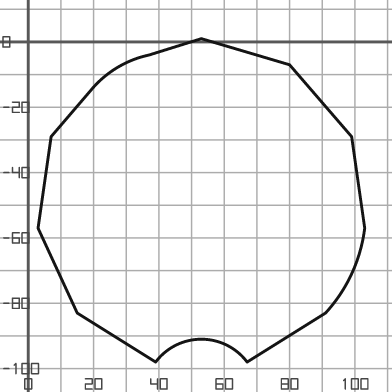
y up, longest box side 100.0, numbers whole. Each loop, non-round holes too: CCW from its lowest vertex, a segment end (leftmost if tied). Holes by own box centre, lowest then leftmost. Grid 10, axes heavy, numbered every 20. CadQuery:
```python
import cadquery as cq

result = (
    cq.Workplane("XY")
    .moveTo(39.0, -98.0)
    .threePointArc((53.0, -91.0), (67.0, -98.0))
    .lineTo(91.0, -83.0)
    .threePointArc((99.0, -71.0), (103.0, -57.0))
    .lineTo(99.0, -29.0)
    .lineTo(80.0, -7.0)
    .lineTo(53.0, 1.0)
    .lineTo(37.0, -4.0)
    .threePointArc((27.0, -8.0), (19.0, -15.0))
    .lineTo(7.0, -29.0)
    .lineTo(3.0, -57.0)
    .lineTo(15.0, -83.0)
    .close()
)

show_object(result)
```